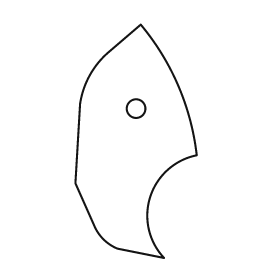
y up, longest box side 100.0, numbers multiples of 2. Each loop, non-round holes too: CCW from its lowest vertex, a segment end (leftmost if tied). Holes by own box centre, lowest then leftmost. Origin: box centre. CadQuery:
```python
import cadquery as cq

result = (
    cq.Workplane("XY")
    .moveTo(12.0, -50.0)
    .threePointArc((6.0, -24.0), (26.0, -6.0))
    .threePointArc((18.0, 24.0), (2.0, 50.0))
    .lineTo(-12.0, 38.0)
    .threePointArc((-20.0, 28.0), (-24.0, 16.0))
    .lineTo(-26.0, -18.0)
    .lineTo(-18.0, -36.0)
    .threePointArc((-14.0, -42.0), (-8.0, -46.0))
    .close()
    .moveTo(0.0, 14.0)
    .circle(4.0)
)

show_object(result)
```